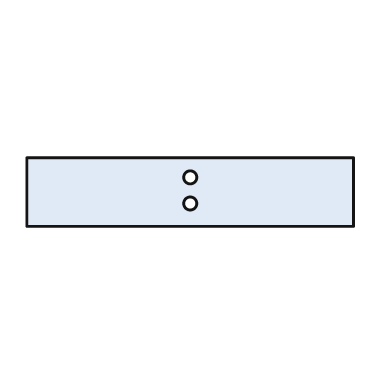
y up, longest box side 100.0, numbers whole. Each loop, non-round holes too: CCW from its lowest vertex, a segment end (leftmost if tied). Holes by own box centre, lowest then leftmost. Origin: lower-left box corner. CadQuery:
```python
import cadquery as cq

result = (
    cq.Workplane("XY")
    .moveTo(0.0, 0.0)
    .lineTo(100.0, 0.0)
    .lineTo(100.0, 21.0)
    .lineTo(0.0, 21.0)
    .close()
    .moveTo(50.0, 7.0)
    .circle(2.0)
    .moveTo(50.0, 15.0)
    .circle(2.0)
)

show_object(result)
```